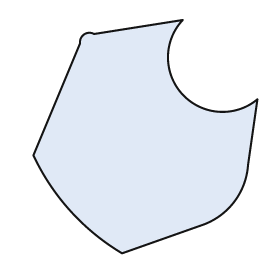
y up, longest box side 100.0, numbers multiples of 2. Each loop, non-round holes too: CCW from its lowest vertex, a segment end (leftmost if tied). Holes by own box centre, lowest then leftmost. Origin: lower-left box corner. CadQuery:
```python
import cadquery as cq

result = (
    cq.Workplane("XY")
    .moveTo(38.0, 0.0)
    .lineTo(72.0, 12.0)
    .threePointArc((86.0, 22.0), (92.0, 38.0))
    .lineTo(96.0, 66.0)
    .threePointArc((64.0, 68.0), (64.0, 100.0))
    .lineTo(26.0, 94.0)
    .threePointArc((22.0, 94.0), (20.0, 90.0))
    .lineTo(0.0, 42.0)
    .threePointArc((16.0, 18.0), (38.0, 0.0))
    .close()
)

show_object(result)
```